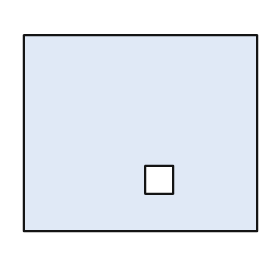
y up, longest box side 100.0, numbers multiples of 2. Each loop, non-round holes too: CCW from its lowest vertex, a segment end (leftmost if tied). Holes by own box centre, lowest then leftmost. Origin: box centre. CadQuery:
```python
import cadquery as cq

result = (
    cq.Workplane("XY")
    .moveTo(-50.0, -42.0)
    .lineTo(50.0, -42.0)
    .lineTo(50.0, 42.0)
    .lineTo(-50.0, 42.0)
    .close()
    .moveTo(2.0, -26.0)
    .lineTo(14.0, -26.0)
    .lineTo(14.0, -14.0)
    .lineTo(2.0, -14.0)
    .close()
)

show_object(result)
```